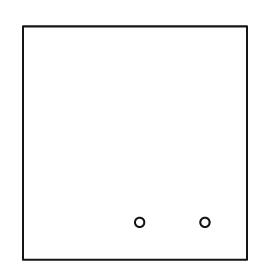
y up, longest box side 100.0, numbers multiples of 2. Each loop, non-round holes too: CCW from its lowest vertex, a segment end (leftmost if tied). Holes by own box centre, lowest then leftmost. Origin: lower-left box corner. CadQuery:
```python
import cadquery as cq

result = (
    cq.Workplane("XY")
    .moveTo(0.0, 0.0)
    .lineTo(96.0, 0.0)
    .lineTo(96.0, 100.0)
    .lineTo(0.0, 100.0)
    .close()
    .moveTo(50.0, 16.0)
    .circle(2.0)
    .moveTo(78.0, 16.0)
    .circle(2.0)
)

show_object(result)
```